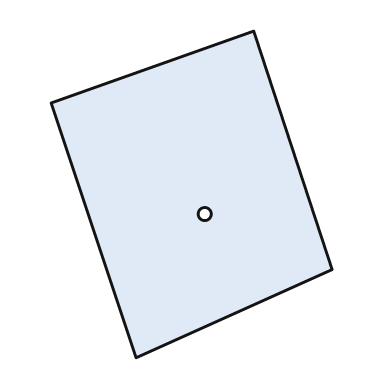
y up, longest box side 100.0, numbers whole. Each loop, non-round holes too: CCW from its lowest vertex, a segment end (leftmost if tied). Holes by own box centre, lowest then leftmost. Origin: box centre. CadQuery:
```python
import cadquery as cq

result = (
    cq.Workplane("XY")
    .moveTo(-17.0, -50.0)
    .lineTo(43.0, -23.0)
    .lineTo(19.0, 50.0)
    .lineTo(-43.0, 28.0)
    .close()
    .moveTo(4.0, -6.0)
    .circle(2.0)
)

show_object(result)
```